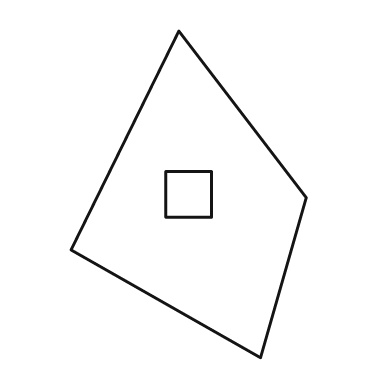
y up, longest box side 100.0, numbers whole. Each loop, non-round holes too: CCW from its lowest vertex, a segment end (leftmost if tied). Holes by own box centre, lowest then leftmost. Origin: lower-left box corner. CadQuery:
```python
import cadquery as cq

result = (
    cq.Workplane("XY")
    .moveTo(58.0, 0.0)
    .lineTo(72.0, 49.0)
    .lineTo(33.0, 100.0)
    .lineTo(0.0, 33.0)
    .close()
    .moveTo(29.0, 43.0)
    .lineTo(43.0, 43.0)
    .lineTo(43.0, 57.0)
    .lineTo(29.0, 57.0)
    .close()
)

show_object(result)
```